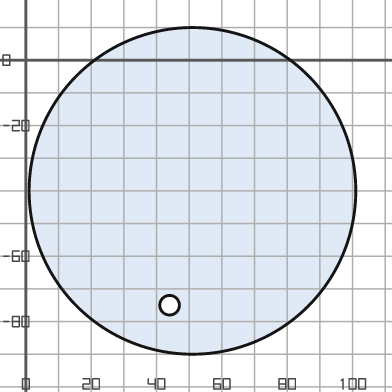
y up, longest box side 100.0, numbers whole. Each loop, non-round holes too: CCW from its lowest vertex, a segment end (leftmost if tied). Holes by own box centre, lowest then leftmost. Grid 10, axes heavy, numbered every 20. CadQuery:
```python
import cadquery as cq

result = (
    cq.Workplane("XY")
    .moveTo(51.0, -40.0)
    .circle(50.0)
    .moveTo(44.0, -75.0)
    .circle(3.0)
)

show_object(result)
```